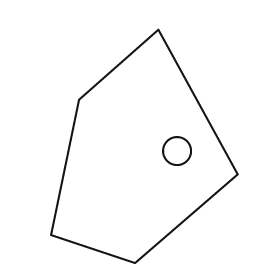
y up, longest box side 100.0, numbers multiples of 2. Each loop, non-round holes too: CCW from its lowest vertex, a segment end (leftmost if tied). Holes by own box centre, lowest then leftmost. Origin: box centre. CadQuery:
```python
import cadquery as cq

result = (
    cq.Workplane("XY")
    .moveTo(-4.0, -50.0)
    .lineTo(40.0, -12.0)
    .lineTo(6.0, 50.0)
    .lineTo(-28.0, 20.0)
    .lineTo(-40.0, -38.0)
    .close()
    .moveTo(14.0, -2.0)
    .circle(6.0)
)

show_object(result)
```